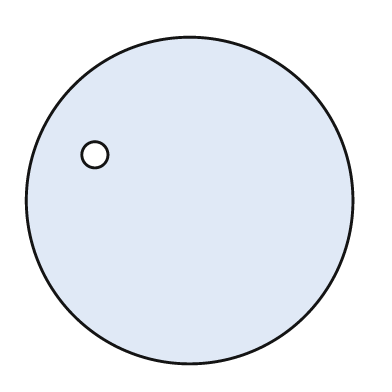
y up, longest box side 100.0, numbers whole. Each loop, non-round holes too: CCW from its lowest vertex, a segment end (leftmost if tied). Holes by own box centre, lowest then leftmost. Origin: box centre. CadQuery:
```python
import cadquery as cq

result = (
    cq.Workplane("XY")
    .moveTo(0.0, 0.0)
    .circle(50.0)
    .moveTo(-29.0, 14.0)
    .circle(4.0)
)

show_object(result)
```